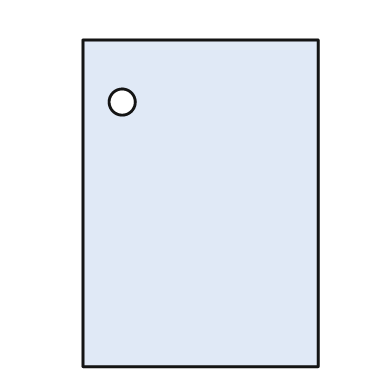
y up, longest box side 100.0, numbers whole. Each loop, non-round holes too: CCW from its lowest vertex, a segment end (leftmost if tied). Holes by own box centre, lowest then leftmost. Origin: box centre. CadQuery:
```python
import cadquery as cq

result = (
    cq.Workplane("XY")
    .moveTo(-36.0, -50.0)
    .lineTo(36.0, -50.0)
    .lineTo(36.0, 50.0)
    .lineTo(-36.0, 50.0)
    .close()
    .moveTo(-24.0, 31.0)
    .circle(4.0)
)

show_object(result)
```